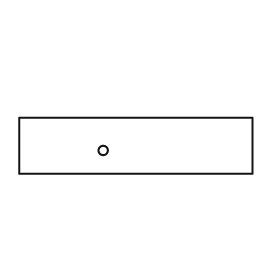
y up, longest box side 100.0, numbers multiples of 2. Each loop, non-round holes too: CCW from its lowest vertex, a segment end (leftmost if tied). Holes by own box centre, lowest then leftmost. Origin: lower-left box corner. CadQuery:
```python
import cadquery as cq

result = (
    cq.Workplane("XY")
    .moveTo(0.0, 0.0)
    .lineTo(100.0, 0.0)
    .lineTo(100.0, 24.0)
    .lineTo(0.0, 24.0)
    .close()
    .moveTo(36.0, 10.0)
    .circle(2.0)
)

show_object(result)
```